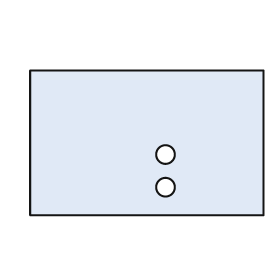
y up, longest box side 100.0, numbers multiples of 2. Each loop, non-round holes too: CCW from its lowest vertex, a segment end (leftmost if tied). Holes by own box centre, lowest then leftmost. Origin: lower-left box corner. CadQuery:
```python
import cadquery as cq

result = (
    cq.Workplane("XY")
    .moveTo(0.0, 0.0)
    .lineTo(100.0, 0.0)
    .lineTo(100.0, 62.0)
    .lineTo(0.0, 62.0)
    .close()
    .moveTo(58.0, 12.0)
    .circle(4.0)
    .moveTo(58.0, 26.0)
    .circle(4.0)
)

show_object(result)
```